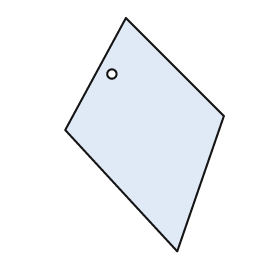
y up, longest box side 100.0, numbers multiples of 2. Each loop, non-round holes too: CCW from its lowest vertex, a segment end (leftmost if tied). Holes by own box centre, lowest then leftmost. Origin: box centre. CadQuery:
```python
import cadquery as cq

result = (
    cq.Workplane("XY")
    .moveTo(14.0, -50.0)
    .lineTo(34.0, 8.0)
    .lineTo(-8.0, 50.0)
    .lineTo(-34.0, 2.0)
    .close()
    .moveTo(-14.0, 26.0)
    .circle(2.0)
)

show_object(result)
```